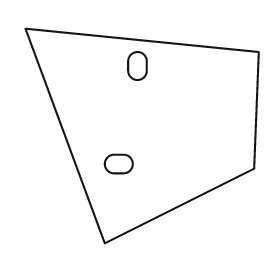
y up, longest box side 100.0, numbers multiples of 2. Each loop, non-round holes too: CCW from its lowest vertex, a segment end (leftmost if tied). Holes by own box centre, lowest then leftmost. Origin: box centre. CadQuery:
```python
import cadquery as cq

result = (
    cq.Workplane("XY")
    .moveTo(-16.0, -46.0)
    .lineTo(48.0, -14.0)
    .lineTo(50.0, 36.0)
    .lineTo(-50.0, 46.0)
    .close()
    .moveTo(-12.0, -16.0)
    .lineTo(-8.0, -16.0)
    .threePointArc((-4.0, -12.0), (-8.0, -8.0))
    .lineTo(-12.0, -8.0)
    .threePointArc((-16.0, -12.0), (-12.0, -16.0))
    .close()
    .moveTo(-6.0, 28.0)
    .threePointArc((-2.0, 24.0), (2.0, 28.0))
    .lineTo(2.0, 32.0)
    .threePointArc((-2.0, 36.0), (-6.0, 32.0))
    .close()
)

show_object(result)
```